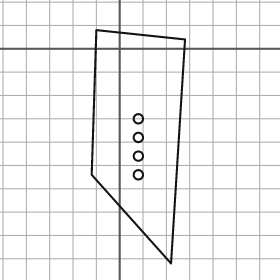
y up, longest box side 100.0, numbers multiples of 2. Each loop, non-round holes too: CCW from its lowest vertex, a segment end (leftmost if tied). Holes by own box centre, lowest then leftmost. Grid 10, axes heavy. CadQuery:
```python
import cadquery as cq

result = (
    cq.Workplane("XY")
    .moveTo(22.0, -92.0)
    .lineTo(28.0, 4.0)
    .lineTo(-10.0, 8.0)
    .lineTo(-12.0, -54.0)
    .close()
    .moveTo(8.0, -54.0)
    .circle(2.0)
    .moveTo(8.0, -46.0)
    .circle(2.0)
    .moveTo(8.0, -38.0)
    .circle(2.0)
    .moveTo(8.0, -30.0)
    .circle(2.0)
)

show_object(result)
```